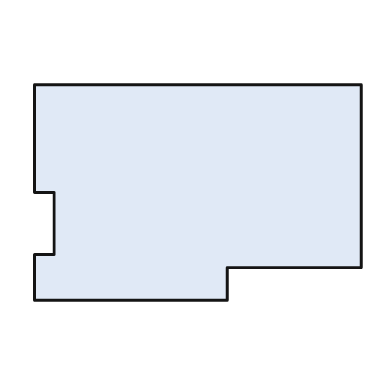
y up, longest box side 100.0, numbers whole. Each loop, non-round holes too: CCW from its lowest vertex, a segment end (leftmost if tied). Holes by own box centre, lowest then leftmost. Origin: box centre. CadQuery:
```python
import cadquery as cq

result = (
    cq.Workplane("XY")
    .moveTo(-50.0, -33.0)
    .lineTo(9.0, -33.0)
    .lineTo(9.0, -23.0)
    .lineTo(50.0, -23.0)
    .lineTo(50.0, 33.0)
    .lineTo(-50.0, 33.0)
    .lineTo(-50.0, 0.0)
    .lineTo(-44.0, 0.0)
    .lineTo(-44.0, -19.0)
    .lineTo(-50.0, -19.0)
    .close()
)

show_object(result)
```